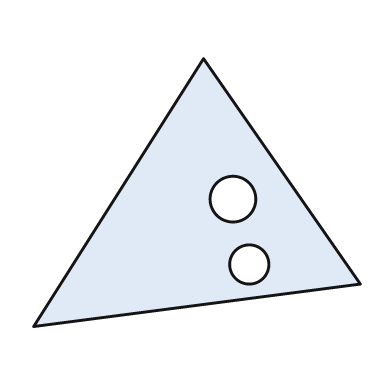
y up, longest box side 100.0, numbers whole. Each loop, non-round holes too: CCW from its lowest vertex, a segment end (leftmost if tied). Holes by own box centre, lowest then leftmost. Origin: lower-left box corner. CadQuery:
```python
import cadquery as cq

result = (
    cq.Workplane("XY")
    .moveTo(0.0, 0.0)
    .lineTo(100.0, 13.0)
    .lineTo(52.0, 82.0)
    .close()
    .moveTo(66.0, 19.0)
    .circle(6.0)
    .moveTo(61.0, 39.0)
    .circle(7.0)
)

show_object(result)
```